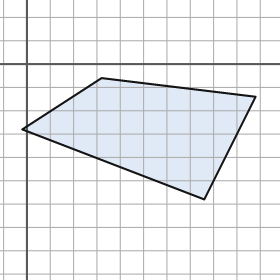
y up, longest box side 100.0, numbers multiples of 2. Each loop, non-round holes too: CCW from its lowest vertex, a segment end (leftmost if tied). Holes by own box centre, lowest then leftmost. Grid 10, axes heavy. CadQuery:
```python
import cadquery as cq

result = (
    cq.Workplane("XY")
    .moveTo(76.0, -58.0)
    .lineTo(98.0, -14.0)
    .lineTo(32.0, -6.0)
    .lineTo(-2.0, -28.0)
    .close()
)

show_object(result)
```